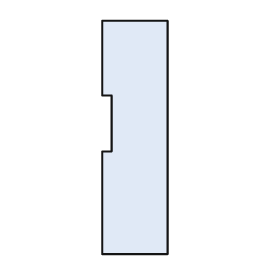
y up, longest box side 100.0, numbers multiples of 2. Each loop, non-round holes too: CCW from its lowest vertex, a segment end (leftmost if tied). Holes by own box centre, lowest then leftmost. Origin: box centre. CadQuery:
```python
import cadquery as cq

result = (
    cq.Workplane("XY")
    .moveTo(-14.0, -50.0)
    .lineTo(14.0, -50.0)
    .lineTo(14.0, 50.0)
    .lineTo(-14.0, 50.0)
    .lineTo(-14.0, 18.0)
    .lineTo(-10.0, 18.0)
    .lineTo(-10.0, -6.0)
    .lineTo(-14.0, -6.0)
    .close()
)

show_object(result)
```